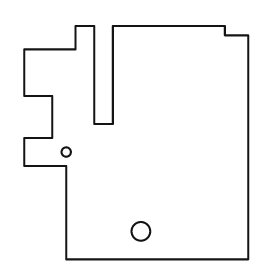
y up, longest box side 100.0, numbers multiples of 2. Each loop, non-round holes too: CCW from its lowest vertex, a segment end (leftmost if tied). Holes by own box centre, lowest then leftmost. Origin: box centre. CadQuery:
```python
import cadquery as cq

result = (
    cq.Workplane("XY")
    .moveTo(-30.0, -50.0)
    .lineTo(48.0, -50.0)
    .lineTo(48.0, 46.0)
    .lineTo(38.0, 46.0)
    .lineTo(38.0, 50.0)
    .lineTo(-10.0, 50.0)
    .lineTo(-10.0, 8.0)
    .lineTo(-18.0, 8.0)
    .lineTo(-18.0, 50.0)
    .lineTo(-26.0, 50.0)
    .lineTo(-26.0, 40.0)
    .lineTo(-48.0, 40.0)
    .lineTo(-48.0, 20.0)
    .lineTo(-36.0, 20.0)
    .lineTo(-36.0, 2.0)
    .lineTo(-48.0, 2.0)
    .lineTo(-48.0, -10.0)
    .lineTo(-30.0, -10.0)
    .close()
    .moveTo(2.0, -38.0)
    .circle(4.0)
    .moveTo(-30.0, -4.0)
    .circle(2.0)
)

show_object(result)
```